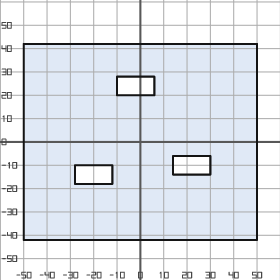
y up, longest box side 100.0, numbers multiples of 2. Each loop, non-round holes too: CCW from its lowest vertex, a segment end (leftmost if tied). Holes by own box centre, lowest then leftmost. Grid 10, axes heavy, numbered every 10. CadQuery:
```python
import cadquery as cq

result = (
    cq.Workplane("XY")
    .moveTo(-50.0, -42.0)
    .lineTo(50.0, -42.0)
    .lineTo(50.0, 42.0)
    .lineTo(-50.0, 42.0)
    .close()
    .moveTo(-28.0, -18.0)
    .lineTo(-12.0, -18.0)
    .lineTo(-12.0, -10.0)
    .lineTo(-28.0, -10.0)
    .close()
    .moveTo(14.0, -14.0)
    .lineTo(30.0, -14.0)
    .lineTo(30.0, -6.0)
    .lineTo(14.0, -6.0)
    .close()
    .moveTo(-10.0, 20.0)
    .lineTo(6.0, 20.0)
    .lineTo(6.0, 28.0)
    .lineTo(-10.0, 28.0)
    .close()
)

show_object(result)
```